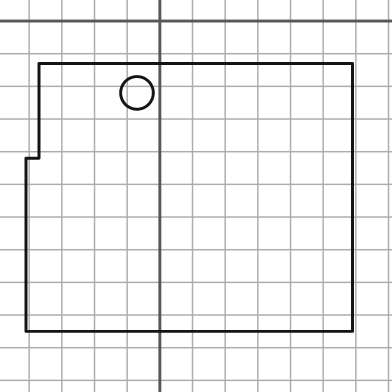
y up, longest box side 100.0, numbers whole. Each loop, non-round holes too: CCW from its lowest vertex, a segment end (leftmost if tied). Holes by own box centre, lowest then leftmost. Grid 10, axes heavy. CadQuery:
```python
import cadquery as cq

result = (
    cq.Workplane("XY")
    .moveTo(-41.0, -95.0)
    .lineTo(59.0, -95.0)
    .lineTo(59.0, -13.0)
    .lineTo(-37.0, -13.0)
    .lineTo(-37.0, -42.0)
    .lineTo(-41.0, -42.0)
    .close()
    .moveTo(-7.0, -22.0)
    .circle(5.0)
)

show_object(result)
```